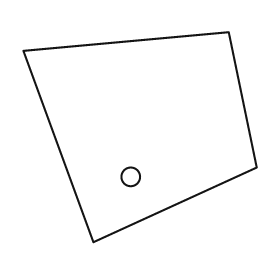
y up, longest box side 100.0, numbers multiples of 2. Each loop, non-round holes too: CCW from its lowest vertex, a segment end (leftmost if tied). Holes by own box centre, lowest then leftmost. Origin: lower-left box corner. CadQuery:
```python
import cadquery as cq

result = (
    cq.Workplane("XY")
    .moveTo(30.0, 0.0)
    .lineTo(100.0, 32.0)
    .lineTo(88.0, 90.0)
    .lineTo(0.0, 82.0)
    .close()
    .moveTo(46.0, 28.0)
    .circle(4.0)
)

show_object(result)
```